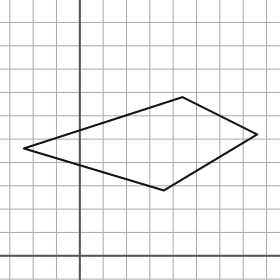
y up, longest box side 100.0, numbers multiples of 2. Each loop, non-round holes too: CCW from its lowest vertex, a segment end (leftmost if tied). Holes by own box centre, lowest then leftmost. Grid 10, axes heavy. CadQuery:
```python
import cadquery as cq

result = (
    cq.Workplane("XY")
    .moveTo(36.0, 28.0)
    .lineTo(76.0, 52.0)
    .lineTo(44.0, 68.0)
    .lineTo(-24.0, 46.0)
    .close()
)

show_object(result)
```